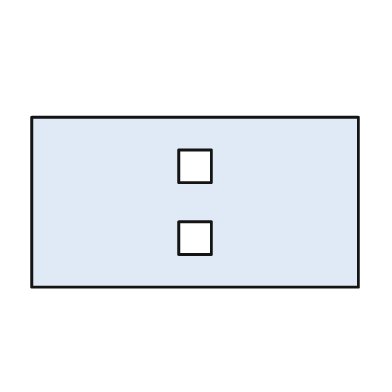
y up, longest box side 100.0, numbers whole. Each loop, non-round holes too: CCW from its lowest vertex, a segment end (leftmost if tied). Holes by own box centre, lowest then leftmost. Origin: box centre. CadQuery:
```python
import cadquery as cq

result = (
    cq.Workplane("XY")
    .moveTo(-50.0, -26.0)
    .lineTo(50.0, -26.0)
    .lineTo(50.0, 26.0)
    .lineTo(-50.0, 26.0)
    .close()
    .moveTo(-5.0, -16.0)
    .lineTo(5.0, -16.0)
    .lineTo(5.0, -6.0)
    .lineTo(-5.0, -6.0)
    .close()
    .moveTo(-5.0, 6.0)
    .lineTo(5.0, 6.0)
    .lineTo(5.0, 16.0)
    .lineTo(-5.0, 16.0)
    .close()
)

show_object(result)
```